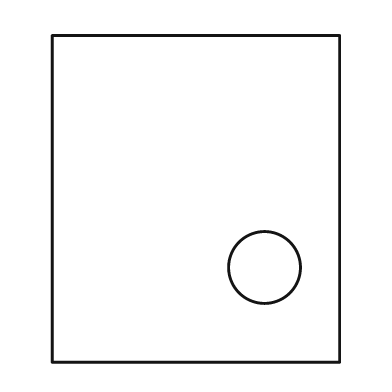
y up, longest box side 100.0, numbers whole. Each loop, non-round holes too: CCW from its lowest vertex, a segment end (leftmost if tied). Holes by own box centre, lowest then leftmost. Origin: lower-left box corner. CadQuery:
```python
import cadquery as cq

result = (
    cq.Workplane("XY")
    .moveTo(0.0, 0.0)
    .lineTo(88.0, 0.0)
    .lineTo(88.0, 100.0)
    .lineTo(0.0, 100.0)
    .close()
    .moveTo(65.0, 29.0)
    .circle(11.0)
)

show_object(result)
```